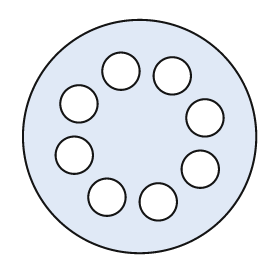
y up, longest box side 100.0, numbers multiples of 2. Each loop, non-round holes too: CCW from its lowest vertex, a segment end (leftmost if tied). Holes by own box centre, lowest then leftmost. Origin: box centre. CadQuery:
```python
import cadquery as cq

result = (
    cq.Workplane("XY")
    .moveTo(0.0, 0.0)
    .circle(50.0)
    .moveTo(8.0, -28.0)
    .circle(8.0)
    .moveTo(-14.0, -26.0)
    .circle(8.0)
    .moveTo(26.0, -14.0)
    .circle(8.0)
    .moveTo(-28.0, -8.0)
    .circle(8.0)
    .moveTo(28.0, 8.0)
    .circle(8.0)
    .moveTo(-26.0, 14.0)
    .circle(8.0)
    .moveTo(14.0, 26.0)
    .circle(8.0)
    .moveTo(-8.0, 28.0)
    .circle(8.0)
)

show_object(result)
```